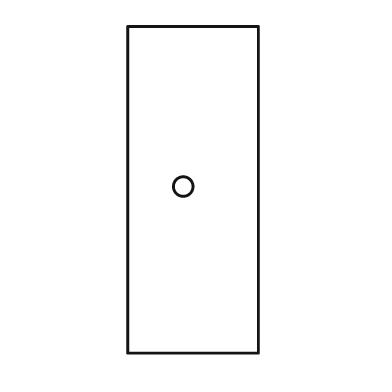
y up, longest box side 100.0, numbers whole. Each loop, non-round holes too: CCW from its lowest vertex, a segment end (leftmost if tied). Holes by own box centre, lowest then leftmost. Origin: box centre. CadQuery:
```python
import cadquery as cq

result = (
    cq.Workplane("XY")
    .moveTo(-20.0, -50.0)
    .lineTo(20.0, -50.0)
    .lineTo(20.0, 50.0)
    .lineTo(-20.0, 50.0)
    .close()
    .moveTo(-3.0, 1.0)
    .circle(3.0)
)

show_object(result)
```